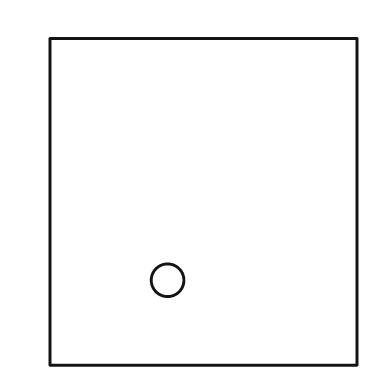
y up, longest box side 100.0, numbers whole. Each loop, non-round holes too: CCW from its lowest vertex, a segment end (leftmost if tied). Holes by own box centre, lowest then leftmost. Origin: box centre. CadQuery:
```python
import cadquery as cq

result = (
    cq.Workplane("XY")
    .moveTo(-47.0, -50.0)
    .lineTo(47.0, -50.0)
    .lineTo(47.0, 50.0)
    .lineTo(-47.0, 50.0)
    .close()
    .moveTo(-11.0, -24.0)
    .circle(5.0)
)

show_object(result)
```